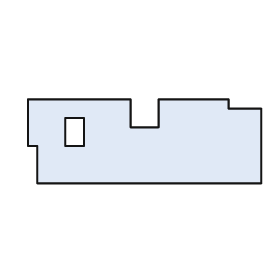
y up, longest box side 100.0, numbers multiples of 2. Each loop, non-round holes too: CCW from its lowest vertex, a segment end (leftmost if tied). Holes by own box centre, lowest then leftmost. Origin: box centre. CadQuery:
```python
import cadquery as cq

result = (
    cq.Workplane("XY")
    .moveTo(-46.0, -18.0)
    .lineTo(50.0, -18.0)
    .lineTo(50.0, 14.0)
    .lineTo(36.0, 14.0)
    .lineTo(36.0, 18.0)
    .lineTo(6.0, 18.0)
    .lineTo(6.0, 6.0)
    .lineTo(-6.0, 6.0)
    .lineTo(-6.0, 18.0)
    .lineTo(-50.0, 18.0)
    .lineTo(-50.0, -2.0)
    .lineTo(-46.0, -2.0)
    .close()
    .moveTo(-34.0, -2.0)
    .lineTo(-26.0, -2.0)
    .lineTo(-26.0, 10.0)
    .lineTo(-34.0, 10.0)
    .close()
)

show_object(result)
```